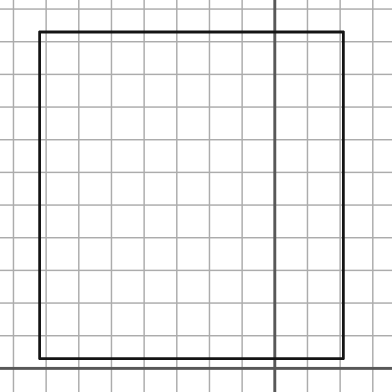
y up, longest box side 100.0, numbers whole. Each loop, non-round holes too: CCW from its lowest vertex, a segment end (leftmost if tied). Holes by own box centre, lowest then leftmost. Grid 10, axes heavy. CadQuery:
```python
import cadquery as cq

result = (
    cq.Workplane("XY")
    .moveTo(-72.0, 3.0)
    .lineTo(21.0, 3.0)
    .lineTo(21.0, 103.0)
    .lineTo(-72.0, 103.0)
    .close()
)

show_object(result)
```